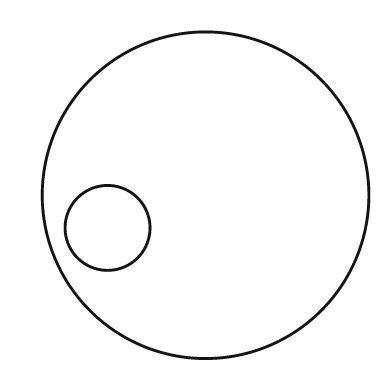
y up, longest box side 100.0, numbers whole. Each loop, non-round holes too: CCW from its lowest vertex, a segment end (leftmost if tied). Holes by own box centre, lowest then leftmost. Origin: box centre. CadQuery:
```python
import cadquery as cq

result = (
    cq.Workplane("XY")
    .moveTo(0.0, 0.0)
    .circle(50.0)
    .moveTo(-30.0, -10.0)
    .circle(13.0)
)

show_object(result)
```